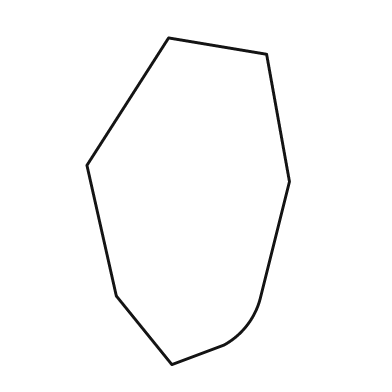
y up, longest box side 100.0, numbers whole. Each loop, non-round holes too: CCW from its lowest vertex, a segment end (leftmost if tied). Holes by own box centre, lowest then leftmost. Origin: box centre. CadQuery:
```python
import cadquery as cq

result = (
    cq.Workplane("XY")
    .moveTo(-5.0, -50.0)
    .lineTo(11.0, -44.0)
    .threePointArc((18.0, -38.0), (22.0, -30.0))
    .lineTo(31.0, 6.0)
    .lineTo(24.0, 45.0)
    .lineTo(-6.0, 50.0)
    .lineTo(-31.0, 11.0)
    .lineTo(-22.0, -29.0)
    .close()
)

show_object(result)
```